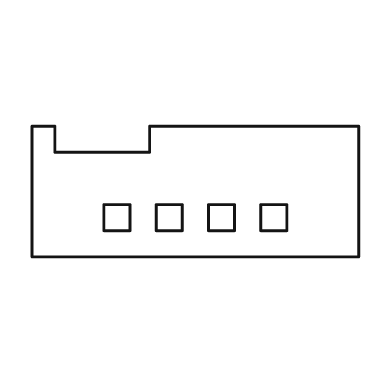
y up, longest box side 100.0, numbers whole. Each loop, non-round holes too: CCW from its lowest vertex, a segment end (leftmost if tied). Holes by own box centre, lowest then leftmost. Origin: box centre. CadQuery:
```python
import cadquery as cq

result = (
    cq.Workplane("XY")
    .moveTo(-50.0, -20.0)
    .lineTo(50.0, -20.0)
    .lineTo(50.0, 20.0)
    .lineTo(-14.0, 20.0)
    .lineTo(-14.0, 12.0)
    .lineTo(-43.0, 12.0)
    .lineTo(-43.0, 20.0)
    .lineTo(-50.0, 20.0)
    .close()
    .moveTo(-28.0, -12.0)
    .lineTo(-20.0, -12.0)
    .lineTo(-20.0, -4.0)
    .lineTo(-28.0, -4.0)
    .close()
    .moveTo(-12.0, -12.0)
    .lineTo(-4.0, -12.0)
    .lineTo(-4.0, -4.0)
    .lineTo(-12.0, -4.0)
    .close()
    .moveTo(4.0, -12.0)
    .lineTo(12.0, -12.0)
    .lineTo(12.0, -4.0)
    .lineTo(4.0, -4.0)
    .close()
    .moveTo(20.0, -12.0)
    .lineTo(28.0, -12.0)
    .lineTo(28.0, -4.0)
    .lineTo(20.0, -4.0)
    .close()
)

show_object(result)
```